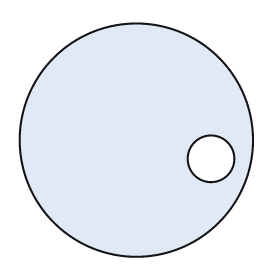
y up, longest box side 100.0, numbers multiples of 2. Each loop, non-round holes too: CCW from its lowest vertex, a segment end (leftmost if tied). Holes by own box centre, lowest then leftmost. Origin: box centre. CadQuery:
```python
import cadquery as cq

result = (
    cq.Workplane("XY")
    .moveTo(0.0, 0.0)
    .circle(50.0)
    .moveTo(32.0, -8.0)
    .circle(10.0)
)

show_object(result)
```